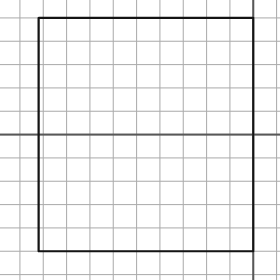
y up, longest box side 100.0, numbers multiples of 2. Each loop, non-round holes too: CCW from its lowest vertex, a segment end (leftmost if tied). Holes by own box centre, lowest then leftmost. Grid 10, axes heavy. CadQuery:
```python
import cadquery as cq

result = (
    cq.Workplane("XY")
    .moveTo(-92.0, -50.0)
    .lineTo(0.0, -50.0)
    .lineTo(0.0, 50.0)
    .lineTo(-92.0, 50.0)
    .close()
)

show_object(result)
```